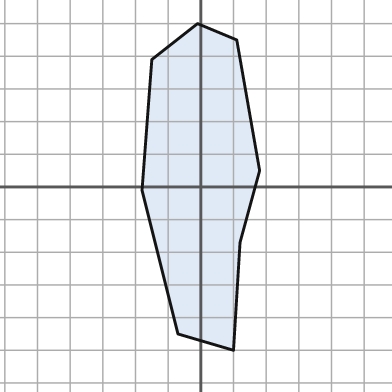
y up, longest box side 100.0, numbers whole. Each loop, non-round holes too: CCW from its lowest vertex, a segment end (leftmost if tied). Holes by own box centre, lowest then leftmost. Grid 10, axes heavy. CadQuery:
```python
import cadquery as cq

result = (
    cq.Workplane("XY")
    .moveTo(10.0, -50.0)
    .lineTo(12.0, -17.0)
    .lineTo(18.0, 5.0)
    .lineTo(11.0, 45.0)
    .lineTo(-1.0, 50.0)
    .lineTo(-15.0, 39.0)
    .lineTo(-18.0, -1.0)
    .lineTo(-7.0, -45.0)
    .close()
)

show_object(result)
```